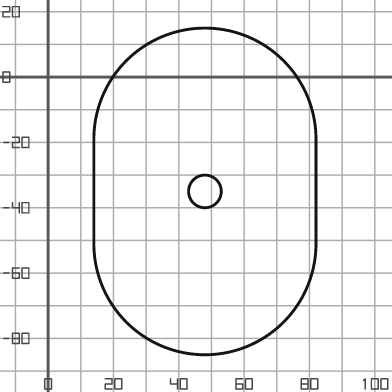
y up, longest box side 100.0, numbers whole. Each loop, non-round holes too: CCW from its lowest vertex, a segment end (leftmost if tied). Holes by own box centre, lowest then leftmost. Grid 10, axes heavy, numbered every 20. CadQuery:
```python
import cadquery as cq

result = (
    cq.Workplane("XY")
    .moveTo(14.0, -51.0)
    .threePointArc((48.0, -85.0), (82.0, -51.0))
    .lineTo(82.0, -19.0)
    .threePointArc((48.0, 15.0), (14.0, -19.0))
    .close()
    .moveTo(48.0, -35.0)
    .circle(5.0)
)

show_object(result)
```